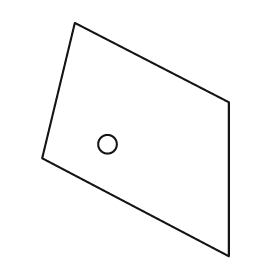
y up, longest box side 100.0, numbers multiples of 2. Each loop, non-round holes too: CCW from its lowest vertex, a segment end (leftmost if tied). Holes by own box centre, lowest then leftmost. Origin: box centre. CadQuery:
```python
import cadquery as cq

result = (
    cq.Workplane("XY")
    .moveTo(40.0, -50.0)
    .lineTo(40.0, 16.0)
    .lineTo(-26.0, 50.0)
    .lineTo(-40.0, -8.0)
    .close()
    .moveTo(-12.0, -2.0)
    .circle(4.0)
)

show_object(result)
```